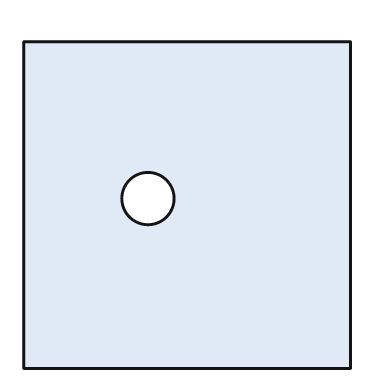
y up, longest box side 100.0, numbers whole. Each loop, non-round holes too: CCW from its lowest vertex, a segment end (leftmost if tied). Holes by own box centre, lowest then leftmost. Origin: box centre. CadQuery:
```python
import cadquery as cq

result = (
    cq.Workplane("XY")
    .moveTo(-50.0, -50.0)
    .lineTo(50.0, -50.0)
    .lineTo(50.0, 50.0)
    .lineTo(-50.0, 50.0)
    .close()
    .moveTo(-12.0, 2.0)
    .circle(8.0)
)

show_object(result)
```